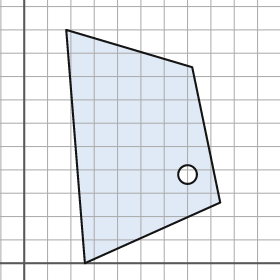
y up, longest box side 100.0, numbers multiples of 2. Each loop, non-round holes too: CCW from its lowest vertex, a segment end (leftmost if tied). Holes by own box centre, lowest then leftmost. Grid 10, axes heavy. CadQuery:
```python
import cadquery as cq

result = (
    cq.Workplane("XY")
    .moveTo(26.0, 0.0)
    .lineTo(84.0, 26.0)
    .lineTo(72.0, 84.0)
    .lineTo(18.0, 100.0)
    .close()
    .moveTo(70.0, 38.0)
    .circle(4.0)
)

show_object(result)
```